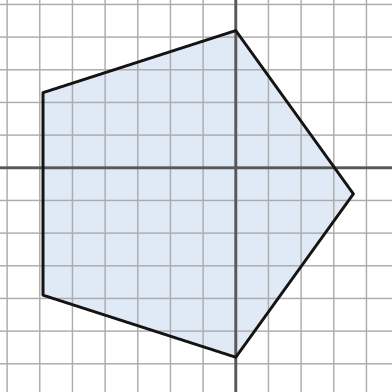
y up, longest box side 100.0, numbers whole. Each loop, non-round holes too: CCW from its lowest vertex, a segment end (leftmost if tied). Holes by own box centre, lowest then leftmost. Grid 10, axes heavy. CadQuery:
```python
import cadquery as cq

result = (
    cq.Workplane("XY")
    .moveTo(0.0, -58.0)
    .lineTo(36.0, -8.0)
    .lineTo(0.0, 42.0)
    .lineTo(-59.0, 23.0)
    .lineTo(-59.0, -39.0)
    .close()
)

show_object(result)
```